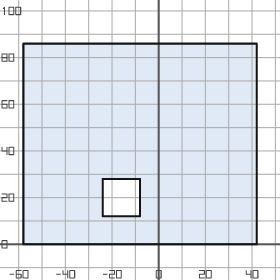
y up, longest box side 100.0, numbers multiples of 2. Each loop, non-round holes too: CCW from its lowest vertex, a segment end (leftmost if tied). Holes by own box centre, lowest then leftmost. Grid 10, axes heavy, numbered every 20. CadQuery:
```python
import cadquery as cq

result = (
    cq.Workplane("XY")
    .moveTo(-58.0, 0.0)
    .lineTo(42.0, 0.0)
    .lineTo(42.0, 86.0)
    .lineTo(-58.0, 86.0)
    .close()
    .moveTo(-24.0, 12.0)
    .lineTo(-8.0, 12.0)
    .lineTo(-8.0, 28.0)
    .lineTo(-24.0, 28.0)
    .close()
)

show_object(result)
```